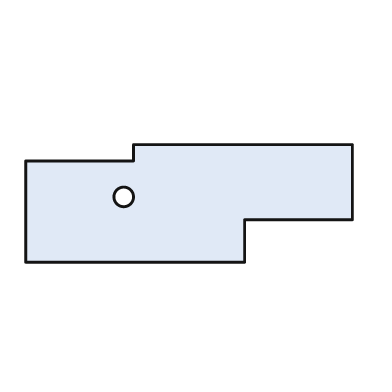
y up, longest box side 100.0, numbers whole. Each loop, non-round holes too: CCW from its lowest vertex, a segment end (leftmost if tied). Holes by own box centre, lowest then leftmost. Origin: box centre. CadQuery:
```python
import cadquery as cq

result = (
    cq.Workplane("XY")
    .moveTo(-50.0, -18.0)
    .lineTo(17.0, -18.0)
    .lineTo(17.0, -5.0)
    .lineTo(50.0, -5.0)
    .lineTo(50.0, 18.0)
    .lineTo(-17.0, 18.0)
    .lineTo(-17.0, 13.0)
    .lineTo(-50.0, 13.0)
    .close()
    .moveTo(-20.0, 2.0)
    .circle(3.0)
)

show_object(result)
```